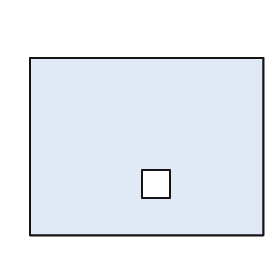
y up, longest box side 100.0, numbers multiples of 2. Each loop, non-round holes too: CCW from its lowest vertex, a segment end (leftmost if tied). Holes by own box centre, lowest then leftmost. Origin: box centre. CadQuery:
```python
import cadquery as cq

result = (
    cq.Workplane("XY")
    .moveTo(-50.0, -38.0)
    .lineTo(50.0, -38.0)
    .lineTo(50.0, 38.0)
    .lineTo(-50.0, 38.0)
    .close()
    .moveTo(-2.0, -22.0)
    .lineTo(10.0, -22.0)
    .lineTo(10.0, -10.0)
    .lineTo(-2.0, -10.0)
    .close()
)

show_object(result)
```